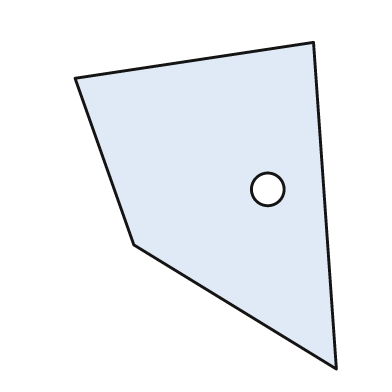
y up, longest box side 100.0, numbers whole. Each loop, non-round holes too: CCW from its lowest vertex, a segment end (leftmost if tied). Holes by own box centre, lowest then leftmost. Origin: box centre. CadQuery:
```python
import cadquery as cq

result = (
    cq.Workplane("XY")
    .moveTo(40.0, -50.0)
    .lineTo(33.0, 50.0)
    .lineTo(-40.0, 39.0)
    .lineTo(-22.0, -12.0)
    .close()
    .moveTo(19.0, 5.0)
    .circle(5.0)
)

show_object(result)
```